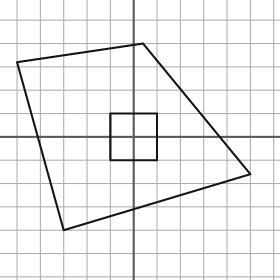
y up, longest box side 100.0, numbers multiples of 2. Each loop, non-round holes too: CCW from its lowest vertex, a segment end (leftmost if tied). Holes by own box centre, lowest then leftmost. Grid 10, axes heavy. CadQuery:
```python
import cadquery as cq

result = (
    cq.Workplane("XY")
    .moveTo(-30.0, -40.0)
    .lineTo(50.0, -16.0)
    .lineTo(4.0, 40.0)
    .lineTo(-50.0, 32.0)
    .close()
    .moveTo(-10.0, -10.0)
    .lineTo(10.0, -10.0)
    .lineTo(10.0, 10.0)
    .lineTo(-10.0, 10.0)
    .close()
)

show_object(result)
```